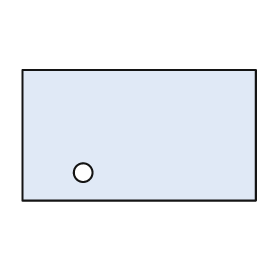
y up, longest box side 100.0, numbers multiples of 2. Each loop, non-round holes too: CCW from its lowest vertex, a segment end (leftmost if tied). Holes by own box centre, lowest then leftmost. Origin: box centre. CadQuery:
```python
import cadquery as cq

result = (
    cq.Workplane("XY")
    .moveTo(-50.0, -28.0)
    .lineTo(50.0, -28.0)
    .lineTo(50.0, 28.0)
    .lineTo(-50.0, 28.0)
    .close()
    .moveTo(-24.0, -16.0)
    .circle(4.0)
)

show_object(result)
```